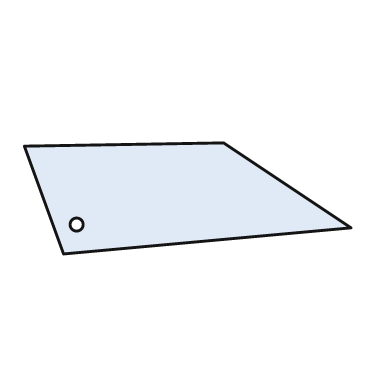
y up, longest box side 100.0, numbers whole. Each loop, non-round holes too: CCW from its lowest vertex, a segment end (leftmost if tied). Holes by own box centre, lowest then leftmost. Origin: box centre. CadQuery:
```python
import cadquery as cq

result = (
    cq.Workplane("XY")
    .moveTo(-38.0, -17.0)
    .lineTo(50.0, -9.0)
    .lineTo(11.0, 17.0)
    .lineTo(-50.0, 16.0)
    .close()
    .moveTo(-34.0, -8.0)
    .circle(2.0)
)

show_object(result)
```